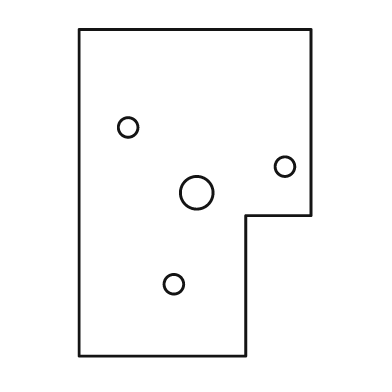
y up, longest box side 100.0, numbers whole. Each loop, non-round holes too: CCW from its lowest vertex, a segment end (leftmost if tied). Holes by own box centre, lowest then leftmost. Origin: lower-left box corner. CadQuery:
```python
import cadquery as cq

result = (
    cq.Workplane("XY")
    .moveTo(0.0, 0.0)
    .lineTo(51.0, 0.0)
    .lineTo(51.0, 43.0)
    .lineTo(71.0, 43.0)
    .lineTo(71.0, 100.0)
    .lineTo(0.0, 100.0)
    .close()
    .moveTo(29.0, 22.0)
    .circle(3.0)
    .moveTo(36.0, 50.0)
    .circle(5.0)
    .moveTo(63.0, 58.0)
    .circle(3.0)
    .moveTo(15.0, 70.0)
    .circle(3.0)
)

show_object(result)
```